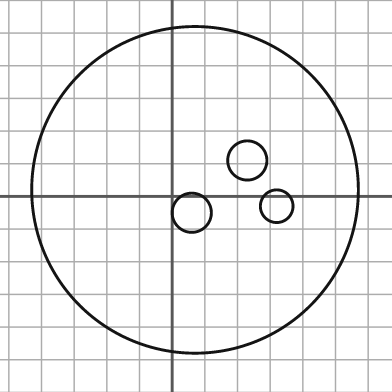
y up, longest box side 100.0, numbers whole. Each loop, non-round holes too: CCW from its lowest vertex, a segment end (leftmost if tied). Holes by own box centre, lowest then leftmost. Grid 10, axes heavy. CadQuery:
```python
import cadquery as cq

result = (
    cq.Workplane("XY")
    .moveTo(7.0, 2.0)
    .circle(50.0)
    .moveTo(6.0, -5.0)
    .circle(6.0)
    .moveTo(32.0, -3.0)
    .circle(5.0)
    .moveTo(23.0, 11.0)
    .circle(6.0)
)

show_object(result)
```